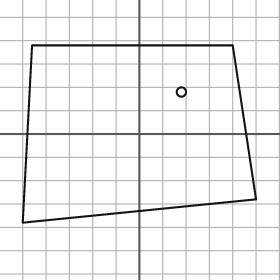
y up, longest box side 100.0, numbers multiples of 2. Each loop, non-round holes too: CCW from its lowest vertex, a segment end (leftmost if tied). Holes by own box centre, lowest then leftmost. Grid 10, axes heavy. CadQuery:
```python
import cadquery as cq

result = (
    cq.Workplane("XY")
    .moveTo(-50.0, -38.0)
    .lineTo(50.0, -28.0)
    .lineTo(40.0, 38.0)
    .lineTo(-46.0, 38.0)
    .close()
    .moveTo(18.0, 18.0)
    .circle(2.0)
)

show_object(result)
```